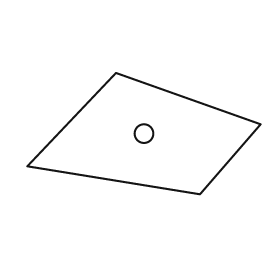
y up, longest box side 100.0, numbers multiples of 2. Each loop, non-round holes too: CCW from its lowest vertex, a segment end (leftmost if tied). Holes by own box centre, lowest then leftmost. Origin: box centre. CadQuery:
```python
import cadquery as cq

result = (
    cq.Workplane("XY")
    .moveTo(24.0, -26.0)
    .lineTo(50.0, 4.0)
    .lineTo(-12.0, 26.0)
    .lineTo(-50.0, -14.0)
    .close()
    .moveTo(0.0, 0.0)
    .circle(4.0)
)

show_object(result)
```